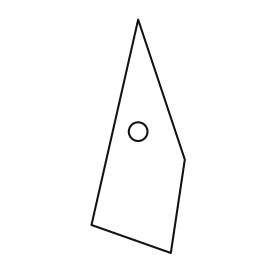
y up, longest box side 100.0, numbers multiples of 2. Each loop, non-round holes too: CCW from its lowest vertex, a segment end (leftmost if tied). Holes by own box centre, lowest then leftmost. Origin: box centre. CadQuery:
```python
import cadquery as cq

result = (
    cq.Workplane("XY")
    .moveTo(14.0, -50.0)
    .lineTo(20.0, -10.0)
    .lineTo(0.0, 50.0)
    .lineTo(-20.0, -38.0)
    .close()
    .moveTo(0.0, 2.0)
    .circle(4.0)
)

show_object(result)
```